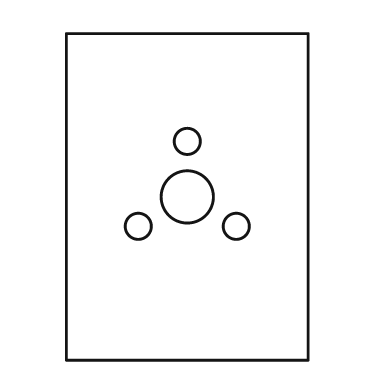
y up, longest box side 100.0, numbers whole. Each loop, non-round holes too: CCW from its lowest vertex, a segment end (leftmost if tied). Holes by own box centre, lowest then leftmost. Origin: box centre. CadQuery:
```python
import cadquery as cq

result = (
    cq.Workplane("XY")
    .moveTo(-37.0, -50.0)
    .lineTo(37.0, -50.0)
    .lineTo(37.0, 50.0)
    .lineTo(-37.0, 50.0)
    .close()
    .moveTo(-15.0, -9.0)
    .circle(4.0)
    .moveTo(15.0, -9.0)
    .circle(4.0)
    .moveTo(0.0, 0.0)
    .circle(8.0)
    .moveTo(0.0, 17.0)
    .circle(4.0)
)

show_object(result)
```